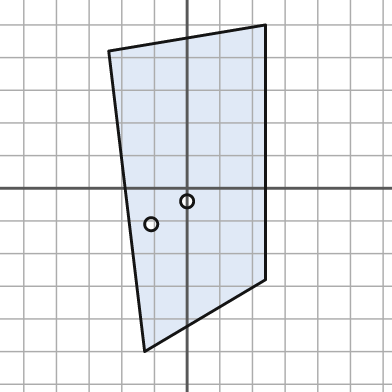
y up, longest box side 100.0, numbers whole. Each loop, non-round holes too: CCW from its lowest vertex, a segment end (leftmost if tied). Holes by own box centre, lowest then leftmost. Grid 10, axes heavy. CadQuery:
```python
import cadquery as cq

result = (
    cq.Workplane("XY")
    .moveTo(-13.0, -50.0)
    .lineTo(24.0, -28.0)
    .lineTo(24.0, 50.0)
    .lineTo(-24.0, 42.0)
    .close()
    .moveTo(-11.0, -11.0)
    .circle(2.0)
    .moveTo(0.0, -4.0)
    .circle(2.0)
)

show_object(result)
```